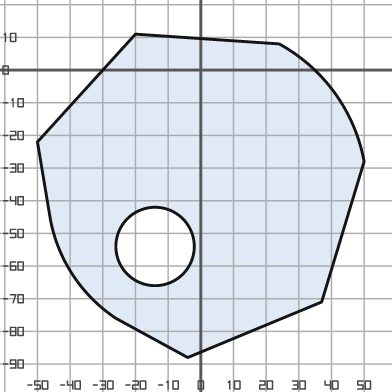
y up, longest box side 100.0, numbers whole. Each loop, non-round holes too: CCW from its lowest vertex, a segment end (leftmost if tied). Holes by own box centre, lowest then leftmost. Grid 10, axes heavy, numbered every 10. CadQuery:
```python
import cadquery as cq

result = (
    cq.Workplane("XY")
    .moveTo(-4.0, -88.0)
    .lineTo(37.0, -71.0)
    .lineTo(50.0, -28.0)
    .threePointArc((41.0, -7.0), (24.0, 8.0))
    .lineTo(-20.0, 11.0)
    .lineTo(-50.0, -22.0)
    .lineTo(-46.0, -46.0)
    .threePointArc((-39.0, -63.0), (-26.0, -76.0))
    .close()
    .moveTo(-14.0, -54.0)
    .circle(12.0)
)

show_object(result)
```